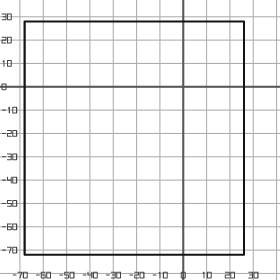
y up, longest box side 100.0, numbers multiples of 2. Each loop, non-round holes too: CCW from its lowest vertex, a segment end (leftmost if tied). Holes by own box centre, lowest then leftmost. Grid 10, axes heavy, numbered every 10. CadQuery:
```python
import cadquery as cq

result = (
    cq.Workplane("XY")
    .moveTo(-68.0, -72.0)
    .lineTo(26.0, -72.0)
    .lineTo(26.0, 28.0)
    .lineTo(-68.0, 28.0)
    .close()
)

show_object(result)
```